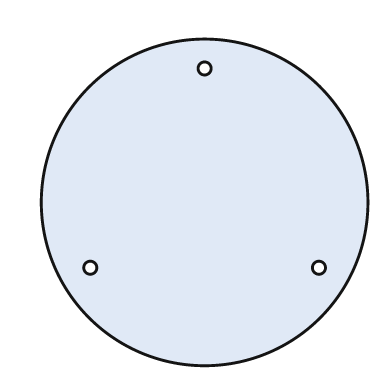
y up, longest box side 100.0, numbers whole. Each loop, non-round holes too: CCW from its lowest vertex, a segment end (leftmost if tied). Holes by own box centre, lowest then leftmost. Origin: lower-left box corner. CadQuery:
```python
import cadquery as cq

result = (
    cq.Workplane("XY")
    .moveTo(50.0, 50.0)
    .circle(50.0)
    .moveTo(15.0, 30.0)
    .circle(2.0)
    .moveTo(85.0, 30.0)
    .circle(2.0)
    .moveTo(50.0, 91.0)
    .circle(2.0)
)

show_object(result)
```